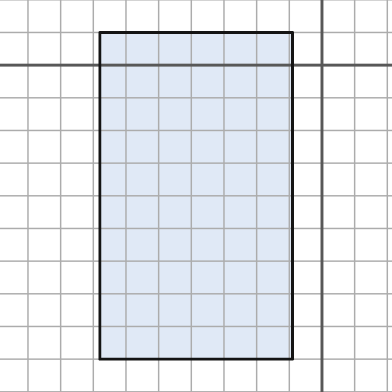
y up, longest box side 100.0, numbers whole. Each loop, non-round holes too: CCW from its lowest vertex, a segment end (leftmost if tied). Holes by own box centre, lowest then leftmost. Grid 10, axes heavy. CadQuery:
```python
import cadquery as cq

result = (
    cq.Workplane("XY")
    .moveTo(-68.0, -90.0)
    .lineTo(-9.0, -90.0)
    .lineTo(-9.0, 10.0)
    .lineTo(-68.0, 10.0)
    .close()
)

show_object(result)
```